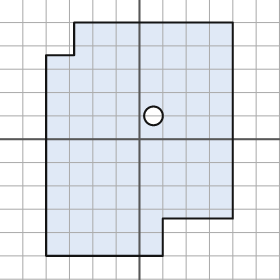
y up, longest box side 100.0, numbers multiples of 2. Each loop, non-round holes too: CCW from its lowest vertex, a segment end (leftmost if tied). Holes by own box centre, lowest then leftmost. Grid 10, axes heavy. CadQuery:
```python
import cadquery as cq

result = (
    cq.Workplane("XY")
    .moveTo(-40.0, -50.0)
    .lineTo(10.0, -50.0)
    .lineTo(10.0, -34.0)
    .lineTo(40.0, -34.0)
    .lineTo(40.0, 50.0)
    .lineTo(-28.0, 50.0)
    .lineTo(-28.0, 36.0)
    .lineTo(-40.0, 36.0)
    .close()
    .moveTo(6.0, 10.0)
    .circle(4.0)
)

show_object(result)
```